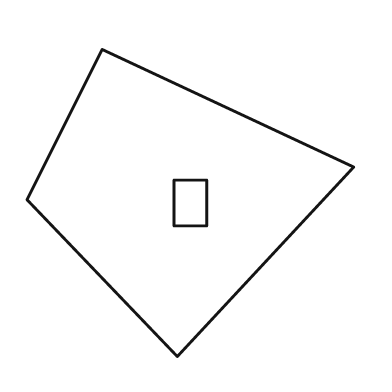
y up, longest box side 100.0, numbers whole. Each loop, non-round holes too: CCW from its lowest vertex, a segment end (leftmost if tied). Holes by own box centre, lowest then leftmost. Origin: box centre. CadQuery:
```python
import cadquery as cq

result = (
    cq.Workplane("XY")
    .moveTo(-4.0, -47.0)
    .lineTo(50.0, 11.0)
    .lineTo(-27.0, 47.0)
    .lineTo(-50.0, 1.0)
    .close()
    .moveTo(-5.0, -7.0)
    .lineTo(5.0, -7.0)
    .lineTo(5.0, 7.0)
    .lineTo(-5.0, 7.0)
    .close()
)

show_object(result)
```